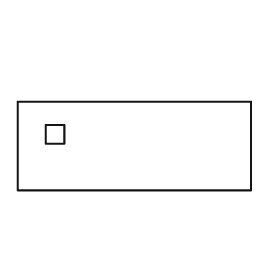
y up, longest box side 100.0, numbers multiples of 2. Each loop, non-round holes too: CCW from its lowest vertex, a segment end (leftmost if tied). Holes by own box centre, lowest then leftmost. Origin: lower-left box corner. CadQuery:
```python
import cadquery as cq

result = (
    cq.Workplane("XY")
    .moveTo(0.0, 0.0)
    .lineTo(100.0, 0.0)
    .lineTo(100.0, 38.0)
    .lineTo(0.0, 38.0)
    .close()
    .moveTo(12.0, 20.0)
    .lineTo(20.0, 20.0)
    .lineTo(20.0, 28.0)
    .lineTo(12.0, 28.0)
    .close()
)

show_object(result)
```